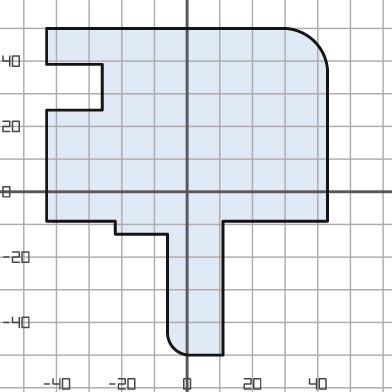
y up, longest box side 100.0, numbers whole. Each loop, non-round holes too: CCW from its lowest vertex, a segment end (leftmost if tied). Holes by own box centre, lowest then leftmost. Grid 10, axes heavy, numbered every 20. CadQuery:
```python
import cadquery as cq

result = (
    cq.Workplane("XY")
    .moveTo(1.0, -50.0)
    .lineTo(11.0, -50.0)
    .lineTo(11.0, -9.0)
    .lineTo(43.0, -9.0)
    .lineTo(43.0, 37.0)
    .threePointArc((39.0, 46.0), (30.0, 50.0))
    .lineTo(-43.0, 50.0)
    .lineTo(-43.0, 39.0)
    .lineTo(-26.0, 39.0)
    .lineTo(-26.0, 25.0)
    .lineTo(-43.0, 25.0)
    .lineTo(-43.0, -9.0)
    .lineTo(-22.0, -9.0)
    .lineTo(-22.0, -13.0)
    .lineTo(-6.0, -13.0)
    .lineTo(-6.0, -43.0)
    .threePointArc((-4.0, -48.0), (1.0, -50.0))
    .close()
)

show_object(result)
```